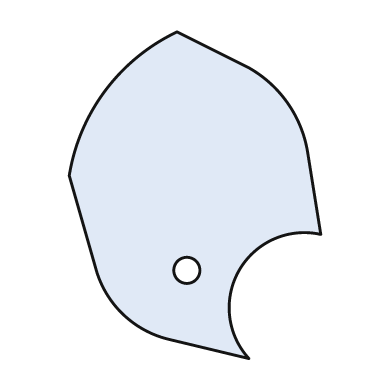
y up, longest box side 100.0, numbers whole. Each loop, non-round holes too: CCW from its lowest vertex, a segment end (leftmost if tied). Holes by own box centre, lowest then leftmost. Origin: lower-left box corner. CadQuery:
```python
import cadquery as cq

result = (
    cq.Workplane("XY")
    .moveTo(55.0, 0.0)
    .threePointArc((52.0, 27.0), (77.0, 38.0))
    .lineTo(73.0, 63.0)
    .threePointArc((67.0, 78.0), (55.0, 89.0))
    .lineTo(33.0, 100.0)
    .threePointArc((11.0, 82.0), (0.0, 56.0))
    .lineTo(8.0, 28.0)
    .threePointArc((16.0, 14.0), (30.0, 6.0))
    .close()
    .moveTo(36.0, 27.0)
    .circle(4.0)
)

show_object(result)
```